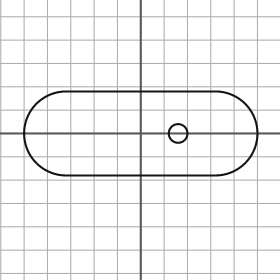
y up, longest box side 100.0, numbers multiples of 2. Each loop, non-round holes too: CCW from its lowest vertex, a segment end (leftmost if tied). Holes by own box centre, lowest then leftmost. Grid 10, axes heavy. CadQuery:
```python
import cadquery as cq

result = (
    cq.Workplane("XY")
    .moveTo(-32.0, -18.0)
    .lineTo(32.0, -18.0)
    .threePointArc((50.0, 0.0), (32.0, 18.0))
    .lineTo(-32.0, 18.0)
    .threePointArc((-50.0, 0.0), (-32.0, -18.0))
    .close()
    .moveTo(16.0, 0.0)
    .circle(4.0)
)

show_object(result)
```